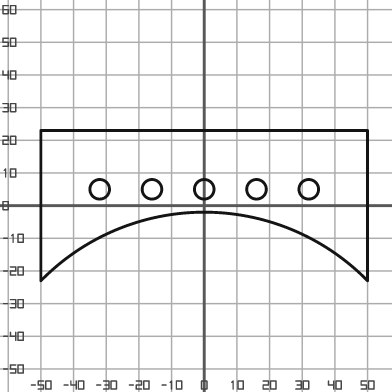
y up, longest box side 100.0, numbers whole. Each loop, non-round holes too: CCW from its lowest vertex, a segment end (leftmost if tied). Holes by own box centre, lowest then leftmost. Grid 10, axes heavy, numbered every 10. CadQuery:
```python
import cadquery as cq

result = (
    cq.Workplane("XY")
    .moveTo(-50.0, -23.0)
    .threePointArc((0.0, -2.0), (50.0, -23.0))
    .lineTo(50.0, 23.0)
    .lineTo(-50.0, 23.0)
    .close()
    .moveTo(-32.0, 5.0)
    .circle(3.0)
    .moveTo(-16.0, 5.0)
    .circle(3.0)
    .moveTo(0.0, 5.0)
    .circle(3.0)
    .moveTo(16.0, 5.0)
    .circle(3.0)
    .moveTo(32.0, 5.0)
    .circle(3.0)
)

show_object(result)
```